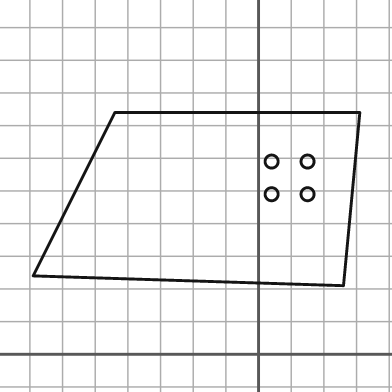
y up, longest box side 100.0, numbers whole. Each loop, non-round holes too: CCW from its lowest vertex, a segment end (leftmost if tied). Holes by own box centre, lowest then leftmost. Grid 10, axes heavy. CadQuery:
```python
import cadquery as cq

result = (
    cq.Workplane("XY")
    .moveTo(26.0, 21.0)
    .lineTo(31.0, 74.0)
    .lineTo(-44.0, 74.0)
    .lineTo(-69.0, 24.0)
    .close()
    .moveTo(4.0, 49.0)
    .circle(2.0)
    .moveTo(15.0, 49.0)
    .circle(2.0)
    .moveTo(4.0, 59.0)
    .circle(2.0)
    .moveTo(15.0, 59.0)
    .circle(2.0)
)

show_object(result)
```